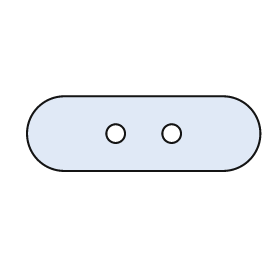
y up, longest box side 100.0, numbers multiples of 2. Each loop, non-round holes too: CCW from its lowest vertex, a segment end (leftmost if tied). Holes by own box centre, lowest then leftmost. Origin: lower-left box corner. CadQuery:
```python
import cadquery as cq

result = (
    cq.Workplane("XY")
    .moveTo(16.0, 0.0)
    .lineTo(84.0, 0.0)
    .threePointArc((100.0, 16.0), (84.0, 32.0))
    .lineTo(16.0, 32.0)
    .threePointArc((0.0, 16.0), (16.0, 0.0))
    .close()
    .moveTo(38.0, 16.0)
    .circle(4.0)
    .moveTo(62.0, 16.0)
    .circle(4.0)
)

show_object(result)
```